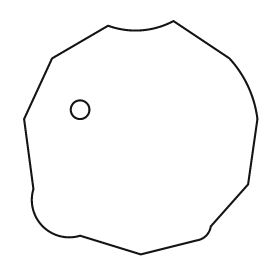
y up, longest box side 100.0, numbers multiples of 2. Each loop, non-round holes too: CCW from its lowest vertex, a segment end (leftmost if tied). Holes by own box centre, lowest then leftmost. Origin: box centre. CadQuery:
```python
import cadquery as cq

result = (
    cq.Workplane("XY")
    .moveTo(0.0, -50.0)
    .lineTo(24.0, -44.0)
    .threePointArc((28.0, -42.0), (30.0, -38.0))
    .lineTo(46.0, -20.0)
    .lineTo(50.0, 8.0)
    .threePointArc((46.0, 22.0), (38.0, 34.0))
    .lineTo(14.0, 50.0)
    .threePointArc((0.0, 46.0), (-14.0, 48.0))
    .lineTo(-38.0, 34.0)
    .lineTo(-50.0, 8.0)
    .lineTo(-46.0, -22.0)
    .threePointArc((-42.0, -38.0), (-26.0, -42.0))
    .close()
    .moveTo(-26.0, 12.0)
    .circle(4.0)
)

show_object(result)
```